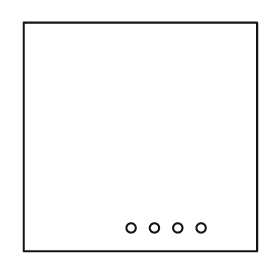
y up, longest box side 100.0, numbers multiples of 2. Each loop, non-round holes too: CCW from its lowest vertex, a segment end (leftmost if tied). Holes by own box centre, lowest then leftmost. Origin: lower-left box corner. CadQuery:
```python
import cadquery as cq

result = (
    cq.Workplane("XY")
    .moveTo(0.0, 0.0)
    .lineTo(100.0, 0.0)
    .lineTo(100.0, 98.0)
    .lineTo(0.0, 98.0)
    .close()
    .moveTo(46.0, 10.0)
    .circle(2.0)
    .moveTo(56.0, 10.0)
    .circle(2.0)
    .moveTo(66.0, 10.0)
    .circle(2.0)
    .moveTo(76.0, 10.0)
    .circle(2.0)
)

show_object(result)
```